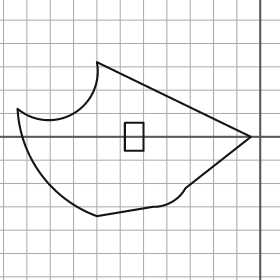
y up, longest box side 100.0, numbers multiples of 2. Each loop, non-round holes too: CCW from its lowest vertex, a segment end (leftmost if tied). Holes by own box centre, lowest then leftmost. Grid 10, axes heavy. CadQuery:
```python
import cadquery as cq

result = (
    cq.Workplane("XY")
    .moveTo(-70.0, -34.0)
    .lineTo(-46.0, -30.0)
    .threePointArc((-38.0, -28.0), (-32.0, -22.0))
    .lineTo(-4.0, 0.0)
    .lineTo(-70.0, 32.0)
    .threePointArc((-80.0, 10.0), (-104.0, 12.0))
    .threePointArc((-94.0, -16.0), (-70.0, -34.0))
    .close()
    .moveTo(-58.0, -6.0)
    .lineTo(-50.0, -6.0)
    .lineTo(-50.0, 6.0)
    .lineTo(-58.0, 6.0)
    .close()
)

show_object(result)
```